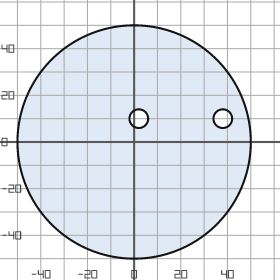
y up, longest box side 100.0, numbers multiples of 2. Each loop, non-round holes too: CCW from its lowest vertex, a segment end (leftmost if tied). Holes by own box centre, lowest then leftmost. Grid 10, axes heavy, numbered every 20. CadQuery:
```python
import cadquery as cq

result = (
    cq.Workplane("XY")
    .moveTo(0.0, 0.0)
    .circle(50.0)
    .moveTo(2.0, 10.0)
    .circle(4.0)
    .moveTo(38.0, 10.0)
    .circle(4.0)
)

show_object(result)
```